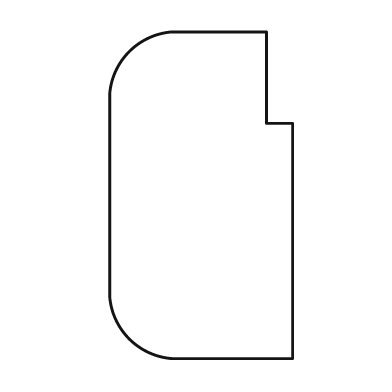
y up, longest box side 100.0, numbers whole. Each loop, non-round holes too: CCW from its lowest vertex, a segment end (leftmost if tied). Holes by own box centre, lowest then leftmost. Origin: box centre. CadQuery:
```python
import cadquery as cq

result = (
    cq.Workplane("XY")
    .moveTo(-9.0, -50.0)
    .lineTo(28.0, -50.0)
    .lineTo(28.0, 22.0)
    .lineTo(20.0, 22.0)
    .lineTo(20.0, 50.0)
    .lineTo(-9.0, 50.0)
    .threePointArc((-22.0, 44.0), (-28.0, 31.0))
    .lineTo(-28.0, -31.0)
    .threePointArc((-22.0, -44.0), (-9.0, -50.0))
    .close()
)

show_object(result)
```